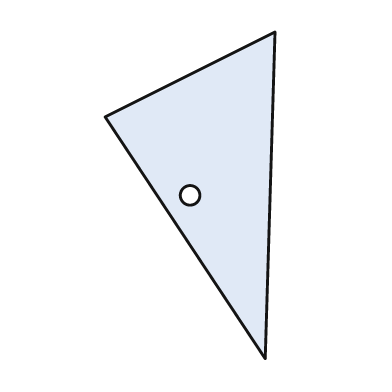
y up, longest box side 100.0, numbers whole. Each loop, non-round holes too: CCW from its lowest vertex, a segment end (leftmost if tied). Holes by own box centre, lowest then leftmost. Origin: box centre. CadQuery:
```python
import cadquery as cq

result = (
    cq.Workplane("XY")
    .moveTo(23.0, -50.0)
    .lineTo(26.0, 50.0)
    .lineTo(-26.0, 24.0)
    .close()
    .moveTo(0.0, 0.0)
    .circle(3.0)
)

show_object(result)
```